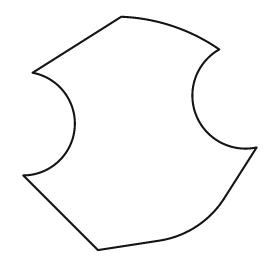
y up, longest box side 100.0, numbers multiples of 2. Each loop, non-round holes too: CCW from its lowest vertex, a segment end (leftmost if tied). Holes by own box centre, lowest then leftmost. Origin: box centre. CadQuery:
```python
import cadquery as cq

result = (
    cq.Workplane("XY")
    .moveTo(-18.0, -50.0)
    .lineTo(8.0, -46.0)
    .threePointArc((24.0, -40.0), (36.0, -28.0))
    .lineTo(50.0, -6.0)
    .threePointArc((24.0, 8.0), (34.0, 36.0))
    .threePointArc((14.0, 46.0), (-8.0, 50.0))
    .lineTo(-46.0, 26.0)
    .threePointArc((-28.0, 2.0), (-50.0, -18.0))
    .close()
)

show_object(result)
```